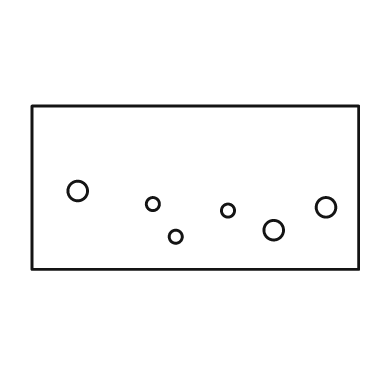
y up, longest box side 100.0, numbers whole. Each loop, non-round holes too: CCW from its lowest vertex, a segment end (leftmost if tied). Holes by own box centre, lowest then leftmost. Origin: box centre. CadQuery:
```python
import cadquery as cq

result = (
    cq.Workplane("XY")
    .moveTo(-50.0, -25.0)
    .lineTo(50.0, -25.0)
    .lineTo(50.0, 25.0)
    .lineTo(-50.0, 25.0)
    .close()
    .moveTo(-6.0, -15.0)
    .circle(2.0)
    .moveTo(24.0, -13.0)
    .circle(3.0)
    .moveTo(10.0, -7.0)
    .circle(2.0)
    .moveTo(40.0, -6.0)
    .circle(3.0)
    .moveTo(-13.0, -5.0)
    .circle(2.0)
    .moveTo(-36.0, -1.0)
    .circle(3.0)
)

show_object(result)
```